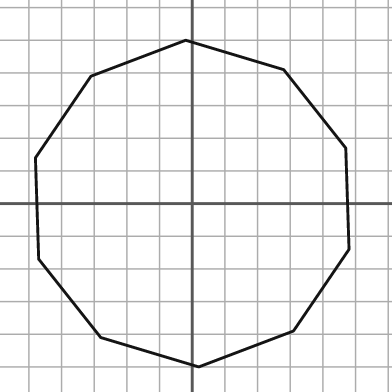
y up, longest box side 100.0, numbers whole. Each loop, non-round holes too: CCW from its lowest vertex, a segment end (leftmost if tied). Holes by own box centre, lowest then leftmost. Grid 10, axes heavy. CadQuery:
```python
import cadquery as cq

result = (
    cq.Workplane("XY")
    .moveTo(2.0, -50.0)
    .lineTo(31.0, -39.0)
    .lineTo(48.0, -14.0)
    .lineTo(47.0, 17.0)
    .lineTo(28.0, 41.0)
    .lineTo(-2.0, 50.0)
    .lineTo(-31.0, 39.0)
    .lineTo(-48.0, 14.0)
    .lineTo(-47.0, -17.0)
    .lineTo(-28.0, -41.0)
    .close()
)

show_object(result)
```